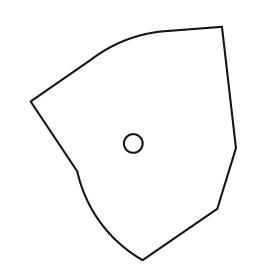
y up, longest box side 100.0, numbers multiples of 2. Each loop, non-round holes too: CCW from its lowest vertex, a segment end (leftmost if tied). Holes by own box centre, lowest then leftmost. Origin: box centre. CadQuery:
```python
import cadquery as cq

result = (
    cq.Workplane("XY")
    .moveTo(4.0, -50.0)
    .lineTo(36.0, -28.0)
    .lineTo(44.0, -2.0)
    .lineTo(38.0, 50.0)
    .lineTo(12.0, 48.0)
    .threePointArc((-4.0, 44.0), (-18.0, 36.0))
    .lineTo(-44.0, 18.0)
    .lineTo(-24.0, -12.0)
    .threePointArc((-14.0, -34.0), (4.0, -50.0))
    .close()
    .moveTo(0.0, 0.0)
    .circle(4.0)
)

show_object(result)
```